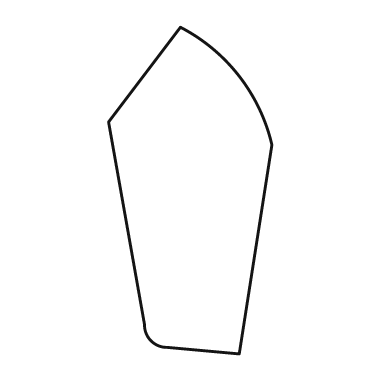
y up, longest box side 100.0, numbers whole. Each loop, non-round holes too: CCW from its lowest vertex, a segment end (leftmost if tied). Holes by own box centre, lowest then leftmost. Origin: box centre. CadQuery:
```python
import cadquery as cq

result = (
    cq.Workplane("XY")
    .moveTo(15.0, -50.0)
    .lineTo(25.0, 14.0)
    .threePointArc((15.0, 35.0), (-3.0, 50.0))
    .lineTo(-25.0, 21.0)
    .lineTo(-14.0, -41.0)
    .threePointArc((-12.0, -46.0), (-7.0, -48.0))
    .close()
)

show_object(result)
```